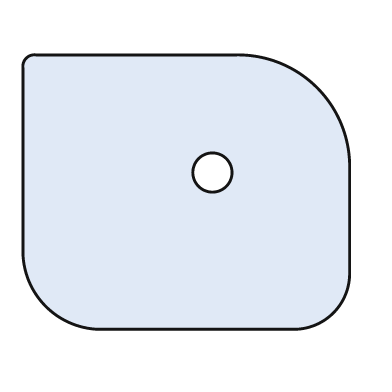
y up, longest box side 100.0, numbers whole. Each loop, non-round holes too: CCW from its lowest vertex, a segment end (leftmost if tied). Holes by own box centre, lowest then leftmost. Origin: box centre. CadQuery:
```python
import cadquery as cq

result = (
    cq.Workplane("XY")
    .moveTo(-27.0, -42.0)
    .lineTo(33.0, -42.0)
    .threePointArc((45.0, -37.0), (50.0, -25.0))
    .lineTo(50.0, 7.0)
    .threePointArc((40.0, 32.0), (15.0, 42.0))
    .lineTo(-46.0, 42.0)
    .threePointArc((-49.0, 41.0), (-50.0, 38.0))
    .lineTo(-50.0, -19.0)
    .threePointArc((-43.0, -35.0), (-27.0, -42.0))
    .close()
    .moveTo(8.0, 6.0)
    .circle(6.0)
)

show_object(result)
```